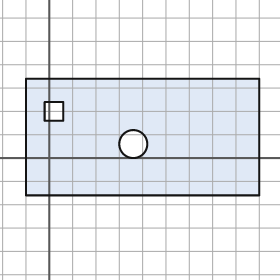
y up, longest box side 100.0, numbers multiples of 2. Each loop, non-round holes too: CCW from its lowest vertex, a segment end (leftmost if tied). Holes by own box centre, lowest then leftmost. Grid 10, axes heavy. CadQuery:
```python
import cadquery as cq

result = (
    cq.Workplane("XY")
    .moveTo(-10.0, -16.0)
    .lineTo(90.0, -16.0)
    .lineTo(90.0, 34.0)
    .lineTo(-10.0, 34.0)
    .close()
    .moveTo(36.0, 6.0)
    .circle(6.0)
    .moveTo(-2.0, 16.0)
    .lineTo(6.0, 16.0)
    .lineTo(6.0, 24.0)
    .lineTo(-2.0, 24.0)
    .close()
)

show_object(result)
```